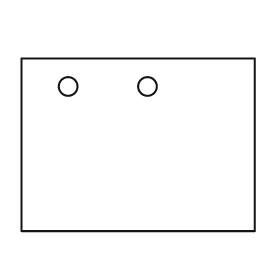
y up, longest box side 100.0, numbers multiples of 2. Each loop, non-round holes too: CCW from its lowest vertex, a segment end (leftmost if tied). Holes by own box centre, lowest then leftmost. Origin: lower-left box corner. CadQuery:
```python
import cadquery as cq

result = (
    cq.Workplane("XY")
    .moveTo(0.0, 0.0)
    .lineTo(100.0, 0.0)
    .lineTo(100.0, 74.0)
    .lineTo(0.0, 74.0)
    .close()
    .moveTo(20.0, 62.0)
    .circle(4.0)
    .moveTo(54.0, 62.0)
    .circle(4.0)
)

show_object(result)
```